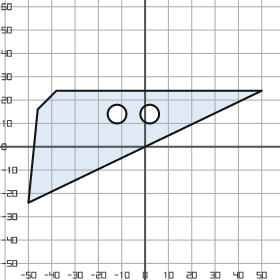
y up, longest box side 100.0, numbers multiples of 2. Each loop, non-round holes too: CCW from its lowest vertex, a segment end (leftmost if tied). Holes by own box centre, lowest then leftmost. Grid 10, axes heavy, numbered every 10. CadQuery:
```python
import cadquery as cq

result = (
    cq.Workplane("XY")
    .moveTo(-50.0, -24.0)
    .lineTo(50.0, 24.0)
    .lineTo(-38.0, 24.0)
    .lineTo(-46.0, 16.0)
    .close()
    .moveTo(-12.0, 14.0)
    .circle(4.0)
    .moveTo(2.0, 14.0)
    .circle(4.0)
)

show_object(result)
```